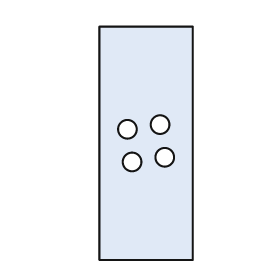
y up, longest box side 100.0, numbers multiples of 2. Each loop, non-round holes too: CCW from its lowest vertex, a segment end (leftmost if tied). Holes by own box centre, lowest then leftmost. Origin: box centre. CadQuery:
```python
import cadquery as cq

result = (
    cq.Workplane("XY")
    .moveTo(-20.0, -50.0)
    .lineTo(20.0, -50.0)
    .lineTo(20.0, 50.0)
    .lineTo(-20.0, 50.0)
    .close()
    .moveTo(-6.0, -8.0)
    .circle(4.0)
    .moveTo(8.0, -6.0)
    .circle(4.0)
    .moveTo(-8.0, 6.0)
    .circle(4.0)
    .moveTo(6.0, 8.0)
    .circle(4.0)
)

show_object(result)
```